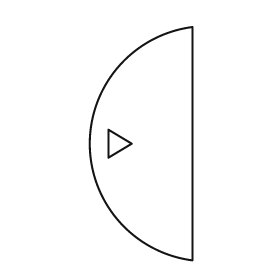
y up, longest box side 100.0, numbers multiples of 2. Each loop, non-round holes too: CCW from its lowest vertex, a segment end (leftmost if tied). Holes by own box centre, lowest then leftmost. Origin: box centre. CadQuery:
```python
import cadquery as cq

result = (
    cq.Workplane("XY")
    .moveTo(22.0, -50.0)
    .lineTo(22.0, 50.0)
    .threePointArc((-22.0, 0.0), (22.0, -50.0))
    .close()
    .moveTo(-14.0, -6.0)
    .lineTo(-4.0, 0.0)
    .lineTo(-14.0, 6.0)
    .close()
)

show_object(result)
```